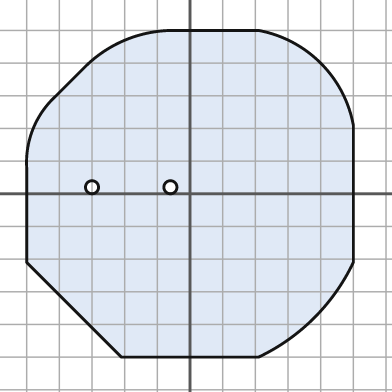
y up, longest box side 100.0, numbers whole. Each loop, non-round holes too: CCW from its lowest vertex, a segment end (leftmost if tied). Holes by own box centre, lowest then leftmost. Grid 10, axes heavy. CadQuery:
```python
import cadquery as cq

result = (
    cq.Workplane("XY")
    .moveTo(-21.0, -50.0)
    .lineTo(21.0, -50.0)
    .threePointArc((38.0, -38.0), (50.0, -21.0))
    .lineTo(50.0, 21.0)
    .threePointArc((40.0, 40.0), (21.0, 50.0))
    .lineTo(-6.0, 50.0)
    .threePointArc((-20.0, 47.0), (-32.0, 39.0))
    .lineTo(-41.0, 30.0)
    .threePointArc((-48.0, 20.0), (-50.0, 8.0))
    .lineTo(-50.0, -21.0)
    .close()
    .moveTo(-30.0, 2.0)
    .circle(2.0)
    .moveTo(-6.0, 2.0)
    .circle(2.0)
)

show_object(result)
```